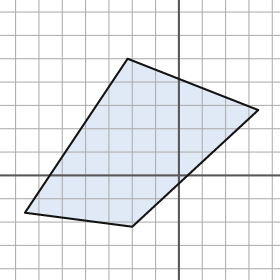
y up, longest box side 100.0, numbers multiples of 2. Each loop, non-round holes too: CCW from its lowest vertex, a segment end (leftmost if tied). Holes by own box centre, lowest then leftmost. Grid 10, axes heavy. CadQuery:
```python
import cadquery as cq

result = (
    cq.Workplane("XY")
    .moveTo(-20.0, -22.0)
    .lineTo(34.0, 28.0)
    .lineTo(-22.0, 50.0)
    .lineTo(-66.0, -16.0)
    .close()
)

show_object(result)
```